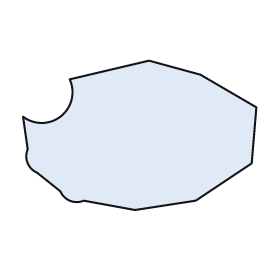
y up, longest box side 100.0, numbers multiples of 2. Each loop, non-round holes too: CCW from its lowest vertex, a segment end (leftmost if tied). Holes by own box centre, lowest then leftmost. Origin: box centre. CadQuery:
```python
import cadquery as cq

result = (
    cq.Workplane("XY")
    .moveTo(-2.0, -32.0)
    .lineTo(24.0, -28.0)
    .lineTo(48.0, -12.0)
    .lineTo(50.0, 12.0)
    .lineTo(26.0, 26.0)
    .lineTo(4.0, 32.0)
    .lineTo(-30.0, 24.0)
    .threePointArc((-34.0, 8.0), (-50.0, 8.0))
    .lineTo(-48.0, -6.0)
    .threePointArc((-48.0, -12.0), (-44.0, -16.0))
    .lineTo(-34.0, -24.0)
    .threePointArc((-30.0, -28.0), (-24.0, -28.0))
    .close()
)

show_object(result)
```